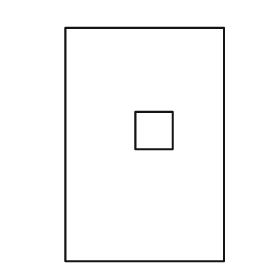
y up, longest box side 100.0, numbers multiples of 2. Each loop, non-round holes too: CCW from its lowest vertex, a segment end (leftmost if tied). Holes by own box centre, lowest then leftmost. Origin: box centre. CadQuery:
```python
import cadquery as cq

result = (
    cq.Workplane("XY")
    .moveTo(-34.0, -50.0)
    .lineTo(34.0, -50.0)
    .lineTo(34.0, 50.0)
    .lineTo(-34.0, 50.0)
    .close()
    .moveTo(-4.0, -2.0)
    .lineTo(12.0, -2.0)
    .lineTo(12.0, 14.0)
    .lineTo(-4.0, 14.0)
    .close()
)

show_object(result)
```